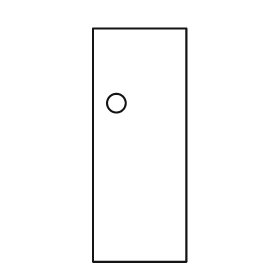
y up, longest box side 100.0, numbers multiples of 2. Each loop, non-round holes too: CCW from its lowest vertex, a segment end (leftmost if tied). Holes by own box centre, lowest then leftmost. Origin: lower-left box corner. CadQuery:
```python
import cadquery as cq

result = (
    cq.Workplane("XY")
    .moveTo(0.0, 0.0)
    .lineTo(40.0, 0.0)
    .lineTo(40.0, 100.0)
    .lineTo(0.0, 100.0)
    .close()
    .moveTo(10.0, 68.0)
    .circle(4.0)
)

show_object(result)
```